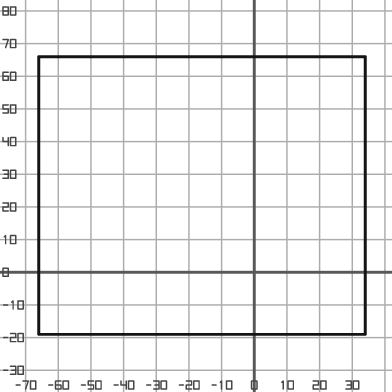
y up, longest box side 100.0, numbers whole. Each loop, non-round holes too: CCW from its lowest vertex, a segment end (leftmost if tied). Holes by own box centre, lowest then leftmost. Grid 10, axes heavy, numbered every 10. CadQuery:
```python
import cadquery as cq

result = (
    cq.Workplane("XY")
    .moveTo(-66.0, -19.0)
    .lineTo(34.0, -19.0)
    .lineTo(34.0, 66.0)
    .lineTo(-66.0, 66.0)
    .close()
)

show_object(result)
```